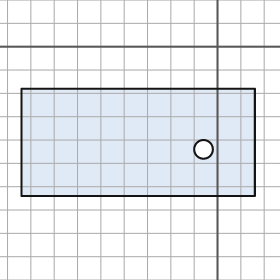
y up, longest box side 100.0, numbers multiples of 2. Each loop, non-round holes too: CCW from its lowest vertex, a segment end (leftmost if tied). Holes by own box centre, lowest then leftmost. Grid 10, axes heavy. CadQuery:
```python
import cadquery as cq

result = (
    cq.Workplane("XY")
    .moveTo(-84.0, -64.0)
    .lineTo(16.0, -64.0)
    .lineTo(16.0, -18.0)
    .lineTo(-84.0, -18.0)
    .close()
    .moveTo(-6.0, -44.0)
    .circle(4.0)
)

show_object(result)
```